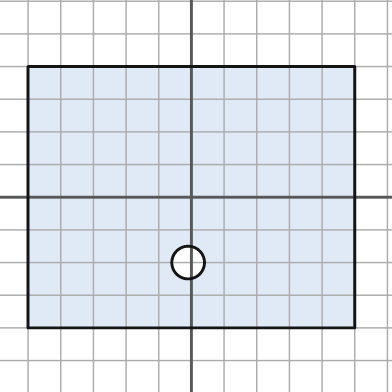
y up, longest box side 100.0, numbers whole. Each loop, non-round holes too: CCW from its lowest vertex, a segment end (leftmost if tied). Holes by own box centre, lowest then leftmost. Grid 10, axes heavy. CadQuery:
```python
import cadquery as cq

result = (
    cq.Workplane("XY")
    .moveTo(-50.0, -40.0)
    .lineTo(50.0, -40.0)
    .lineTo(50.0, 40.0)
    .lineTo(-50.0, 40.0)
    .close()
    .moveTo(-1.0, -20.0)
    .circle(5.0)
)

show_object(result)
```